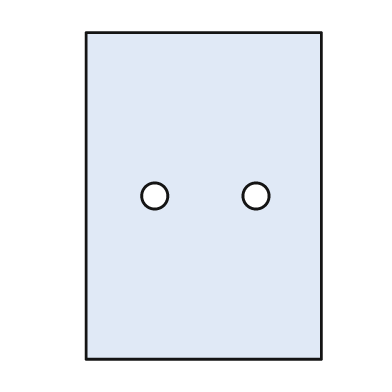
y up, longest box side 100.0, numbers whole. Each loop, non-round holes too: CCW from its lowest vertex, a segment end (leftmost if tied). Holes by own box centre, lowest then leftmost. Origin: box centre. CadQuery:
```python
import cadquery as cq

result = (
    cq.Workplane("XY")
    .moveTo(-36.0, -50.0)
    .lineTo(36.0, -50.0)
    .lineTo(36.0, 50.0)
    .lineTo(-36.0, 50.0)
    .close()
    .moveTo(-15.0, 0.0)
    .circle(4.0)
    .moveTo(16.0, 0.0)
    .circle(4.0)
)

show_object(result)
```